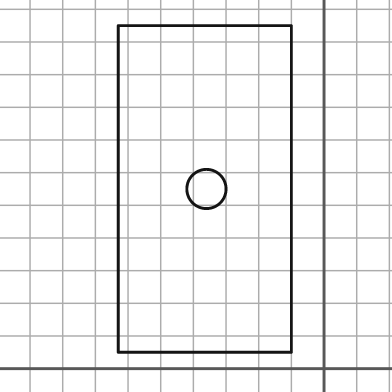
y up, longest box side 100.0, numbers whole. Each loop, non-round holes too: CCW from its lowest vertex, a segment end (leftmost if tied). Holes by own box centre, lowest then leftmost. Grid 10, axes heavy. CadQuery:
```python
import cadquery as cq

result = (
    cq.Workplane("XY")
    .moveTo(-63.0, 5.0)
    .lineTo(-10.0, 5.0)
    .lineTo(-10.0, 105.0)
    .lineTo(-63.0, 105.0)
    .close()
    .moveTo(-36.0, 55.0)
    .circle(6.0)
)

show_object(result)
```